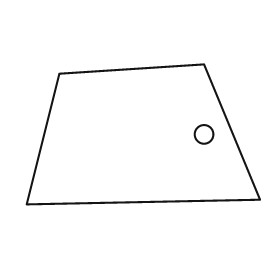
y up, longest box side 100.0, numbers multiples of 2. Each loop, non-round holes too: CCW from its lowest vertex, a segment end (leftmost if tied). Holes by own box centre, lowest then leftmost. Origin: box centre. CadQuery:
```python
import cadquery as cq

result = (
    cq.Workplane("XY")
    .moveTo(-50.0, -30.0)
    .lineTo(50.0, -28.0)
    .lineTo(26.0, 30.0)
    .lineTo(-36.0, 26.0)
    .close()
    .moveTo(26.0, 0.0)
    .circle(4.0)
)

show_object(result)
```